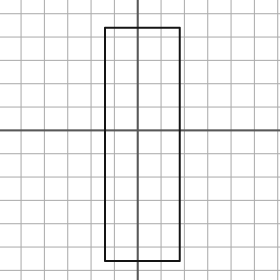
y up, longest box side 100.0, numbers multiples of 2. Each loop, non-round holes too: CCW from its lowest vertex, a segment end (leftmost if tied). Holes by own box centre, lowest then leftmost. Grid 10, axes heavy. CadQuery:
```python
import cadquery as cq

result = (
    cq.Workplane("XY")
    .moveTo(-14.0, -56.0)
    .lineTo(18.0, -56.0)
    .lineTo(18.0, 44.0)
    .lineTo(-14.0, 44.0)
    .close()
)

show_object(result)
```